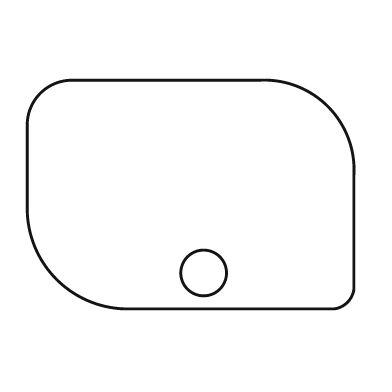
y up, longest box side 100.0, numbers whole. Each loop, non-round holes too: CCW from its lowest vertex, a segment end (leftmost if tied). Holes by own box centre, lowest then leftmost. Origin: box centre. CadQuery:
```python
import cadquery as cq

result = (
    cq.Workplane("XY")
    .moveTo(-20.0, -35.0)
    .lineTo(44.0, -35.0)
    .threePointArc((48.0, -33.0), (50.0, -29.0))
    .lineTo(50.0, 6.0)
    .threePointArc((42.0, 27.0), (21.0, 35.0))
    .lineTo(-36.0, 35.0)
    .threePointArc((-46.0, 31.0), (-50.0, 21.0))
    .lineTo(-50.0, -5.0)
    .threePointArc((-41.0, -26.0), (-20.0, -35.0))
    .close()
    .moveTo(4.0, -24.0)
    .circle(7.0)
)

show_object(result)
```